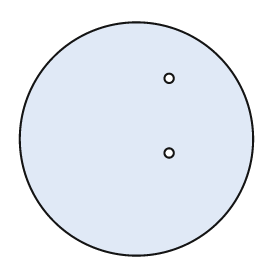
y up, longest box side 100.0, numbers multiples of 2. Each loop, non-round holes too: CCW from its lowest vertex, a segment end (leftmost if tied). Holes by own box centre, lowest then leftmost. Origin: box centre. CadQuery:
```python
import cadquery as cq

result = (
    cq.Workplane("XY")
    .moveTo(0.0, 0.0)
    .circle(50.0)
    .moveTo(14.0, -6.0)
    .circle(2.0)
    .moveTo(14.0, 26.0)
    .circle(2.0)
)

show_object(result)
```